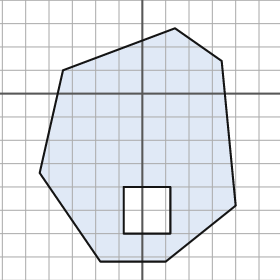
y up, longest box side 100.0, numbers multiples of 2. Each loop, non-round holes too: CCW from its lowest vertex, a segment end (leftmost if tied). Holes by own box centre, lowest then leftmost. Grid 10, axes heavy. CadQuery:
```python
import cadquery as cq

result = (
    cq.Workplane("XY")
    .moveTo(-18.0, -72.0)
    .lineTo(10.0, -72.0)
    .lineTo(40.0, -48.0)
    .lineTo(34.0, 14.0)
    .lineTo(14.0, 28.0)
    .lineTo(-34.0, 10.0)
    .lineTo(-44.0, -34.0)
    .close()
    .moveTo(-8.0, -60.0)
    .lineTo(12.0, -60.0)
    .lineTo(12.0, -40.0)
    .lineTo(-8.0, -40.0)
    .close()
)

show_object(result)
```